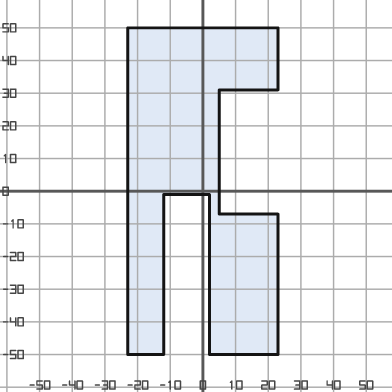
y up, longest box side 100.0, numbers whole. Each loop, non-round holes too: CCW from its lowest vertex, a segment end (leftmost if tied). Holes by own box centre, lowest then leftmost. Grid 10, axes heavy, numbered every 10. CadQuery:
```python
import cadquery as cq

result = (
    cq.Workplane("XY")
    .moveTo(-23.0, -50.0)
    .lineTo(-12.0, -50.0)
    .lineTo(-12.0, -1.0)
    .lineTo(2.0, -1.0)
    .lineTo(2.0, -50.0)
    .lineTo(23.0, -50.0)
    .lineTo(23.0, -7.0)
    .lineTo(5.0, -7.0)
    .lineTo(5.0, 31.0)
    .lineTo(23.0, 31.0)
    .lineTo(23.0, 50.0)
    .lineTo(-23.0, 50.0)
    .close()
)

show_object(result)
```